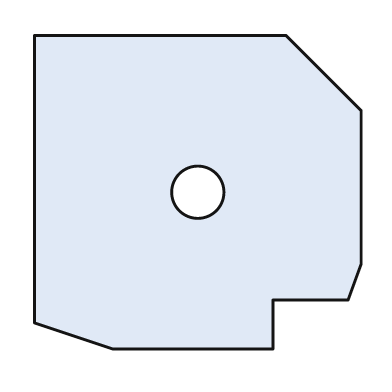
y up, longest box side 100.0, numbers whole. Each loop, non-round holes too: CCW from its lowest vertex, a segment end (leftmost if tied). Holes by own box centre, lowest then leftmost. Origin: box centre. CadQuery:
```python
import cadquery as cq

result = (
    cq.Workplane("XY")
    .moveTo(-26.0, -48.0)
    .lineTo(23.0, -48.0)
    .lineTo(23.0, -33.0)
    .lineTo(46.0, -33.0)
    .lineTo(50.0, -22.0)
    .lineTo(50.0, 25.0)
    .lineTo(27.0, 48.0)
    .lineTo(-50.0, 48.0)
    .lineTo(-50.0, -40.0)
    .close()
    .moveTo(0.0, 0.0)
    .circle(8.0)
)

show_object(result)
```